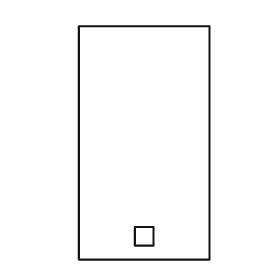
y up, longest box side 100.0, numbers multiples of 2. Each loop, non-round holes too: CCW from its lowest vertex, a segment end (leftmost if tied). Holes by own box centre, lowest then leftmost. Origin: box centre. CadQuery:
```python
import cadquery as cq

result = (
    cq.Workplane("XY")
    .moveTo(-28.0, -50.0)
    .lineTo(28.0, -50.0)
    .lineTo(28.0, 50.0)
    .lineTo(-28.0, 50.0)
    .close()
    .moveTo(-4.0, -44.0)
    .lineTo(4.0, -44.0)
    .lineTo(4.0, -36.0)
    .lineTo(-4.0, -36.0)
    .close()
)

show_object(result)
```